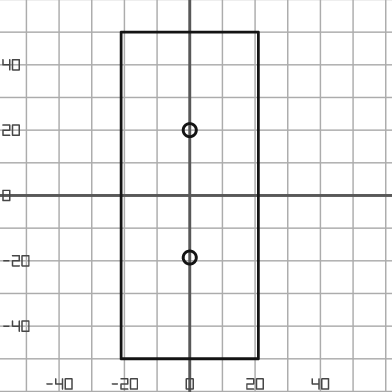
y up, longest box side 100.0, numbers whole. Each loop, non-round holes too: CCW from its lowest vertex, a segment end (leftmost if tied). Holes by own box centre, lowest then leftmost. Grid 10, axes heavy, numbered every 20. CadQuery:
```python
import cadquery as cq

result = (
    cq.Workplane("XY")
    .moveTo(-21.0, -50.0)
    .lineTo(21.0, -50.0)
    .lineTo(21.0, 50.0)
    .lineTo(-21.0, 50.0)
    .close()
    .moveTo(0.0, -19.0)
    .circle(2.0)
    .moveTo(0.0, 20.0)
    .circle(2.0)
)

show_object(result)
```